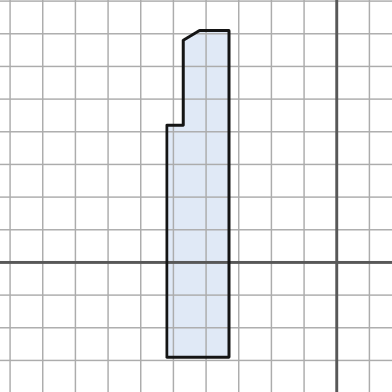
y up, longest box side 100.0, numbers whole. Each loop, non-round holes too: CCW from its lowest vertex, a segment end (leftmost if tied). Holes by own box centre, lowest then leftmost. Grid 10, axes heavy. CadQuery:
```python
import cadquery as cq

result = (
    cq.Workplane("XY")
    .moveTo(-52.0, -29.0)
    .lineTo(-33.0, -29.0)
    .lineTo(-33.0, 71.0)
    .lineTo(-42.0, 71.0)
    .lineTo(-47.0, 68.0)
    .lineTo(-47.0, 42.0)
    .lineTo(-52.0, 42.0)
    .close()
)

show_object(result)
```